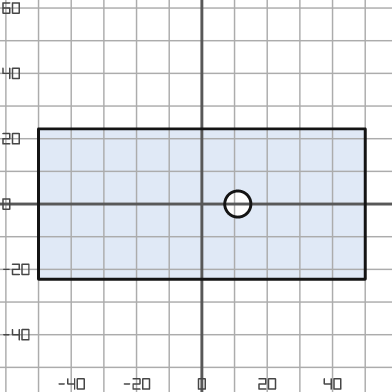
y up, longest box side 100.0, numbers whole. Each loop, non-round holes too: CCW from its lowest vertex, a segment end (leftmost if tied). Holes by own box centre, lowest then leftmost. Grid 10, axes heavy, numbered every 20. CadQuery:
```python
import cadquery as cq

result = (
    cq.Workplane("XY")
    .moveTo(-50.0, -23.0)
    .lineTo(50.0, -23.0)
    .lineTo(50.0, 23.0)
    .lineTo(-50.0, 23.0)
    .close()
    .moveTo(11.0, 0.0)
    .circle(4.0)
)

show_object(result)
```